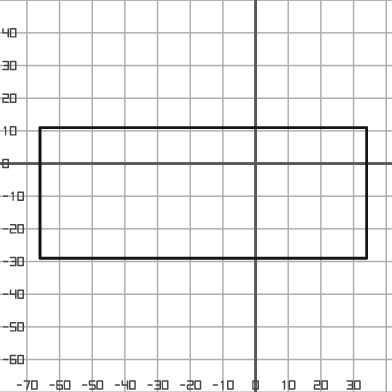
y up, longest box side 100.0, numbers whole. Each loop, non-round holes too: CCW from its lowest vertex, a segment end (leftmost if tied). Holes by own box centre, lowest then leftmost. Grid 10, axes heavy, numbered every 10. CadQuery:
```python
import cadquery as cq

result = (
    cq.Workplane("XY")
    .moveTo(-66.0, -29.0)
    .lineTo(34.0, -29.0)
    .lineTo(34.0, 11.0)
    .lineTo(-66.0, 11.0)
    .close()
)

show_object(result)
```